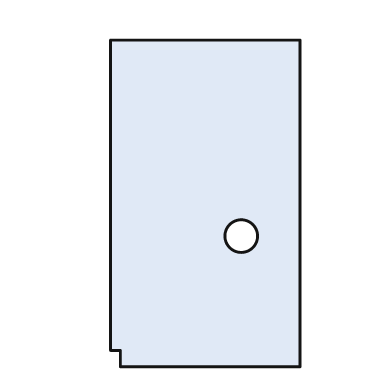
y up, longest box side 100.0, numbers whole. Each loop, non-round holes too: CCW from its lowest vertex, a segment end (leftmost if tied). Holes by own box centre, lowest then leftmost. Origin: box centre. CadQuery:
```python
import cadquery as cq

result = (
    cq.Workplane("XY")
    .moveTo(-26.0, -50.0)
    .lineTo(29.0, -50.0)
    .lineTo(29.0, 50.0)
    .lineTo(-29.0, 50.0)
    .lineTo(-29.0, -45.0)
    .lineTo(-26.0, -45.0)
    .close()
    .moveTo(11.0, -10.0)
    .circle(5.0)
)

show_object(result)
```